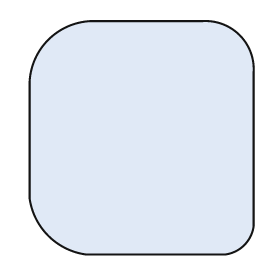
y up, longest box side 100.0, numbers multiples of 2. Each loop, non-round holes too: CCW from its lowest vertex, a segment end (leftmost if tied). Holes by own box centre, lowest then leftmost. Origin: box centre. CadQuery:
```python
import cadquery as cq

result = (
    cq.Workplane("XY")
    .moveTo(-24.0, -50.0)
    .lineTo(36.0, -50.0)
    .threePointArc((44.0, -46.0), (48.0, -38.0))
    .lineTo(48.0, 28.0)
    .threePointArc((42.0, 44.0), (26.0, 50.0))
    .lineTo(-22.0, 50.0)
    .threePointArc((-40.0, 42.0), (-48.0, 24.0))
    .lineTo(-48.0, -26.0)
    .threePointArc((-40.0, -42.0), (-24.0, -50.0))
    .close()
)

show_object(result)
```